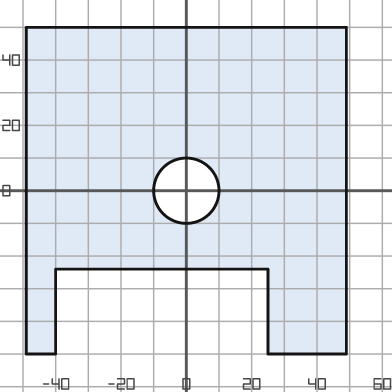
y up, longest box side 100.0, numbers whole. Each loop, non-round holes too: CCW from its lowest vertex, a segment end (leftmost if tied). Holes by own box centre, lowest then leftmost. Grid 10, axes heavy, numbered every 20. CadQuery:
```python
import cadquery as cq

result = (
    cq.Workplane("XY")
    .moveTo(-49.0, -50.0)
    .lineTo(-40.0, -50.0)
    .lineTo(-40.0, -24.0)
    .lineTo(25.0, -24.0)
    .lineTo(25.0, -50.0)
    .lineTo(49.0, -50.0)
    .lineTo(49.0, 50.0)
    .lineTo(-49.0, 50.0)
    .close()
    .moveTo(0.0, 0.0)
    .circle(10.0)
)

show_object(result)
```